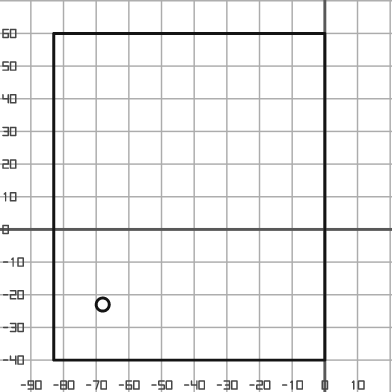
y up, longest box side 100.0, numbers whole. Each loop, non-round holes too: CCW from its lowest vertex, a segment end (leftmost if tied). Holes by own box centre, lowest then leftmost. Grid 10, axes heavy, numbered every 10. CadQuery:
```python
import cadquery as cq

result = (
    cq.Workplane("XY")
    .moveTo(-83.0, -40.0)
    .lineTo(0.0, -40.0)
    .lineTo(0.0, 60.0)
    .lineTo(-83.0, 60.0)
    .close()
    .moveTo(-68.0, -23.0)
    .circle(2.0)
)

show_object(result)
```